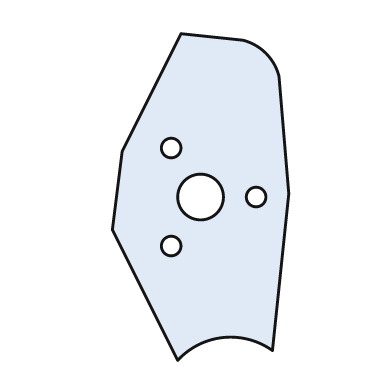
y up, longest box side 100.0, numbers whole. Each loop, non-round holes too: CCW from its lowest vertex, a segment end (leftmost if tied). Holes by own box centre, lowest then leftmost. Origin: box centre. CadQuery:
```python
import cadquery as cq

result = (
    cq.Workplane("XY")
    .moveTo(-7.0, -50.0)
    .threePointArc((7.0, -43.0), (22.0, -47.0))
    .lineTo(27.0, 1.0)
    .lineTo(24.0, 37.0)
    .threePointArc((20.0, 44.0), (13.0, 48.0))
    .lineTo(-6.0, 50.0)
    .lineTo(-24.0, 14.0)
    .lineTo(-27.0, -10.0)
    .close()
    .moveTo(-9.0, -15.0)
    .circle(3.0)
    .moveTo(0.0, 0.0)
    .circle(7.0)
    .moveTo(17.0, 0.0)
    .circle(3.0)
    .moveTo(-9.0, 15.0)
    .circle(3.0)
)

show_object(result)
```